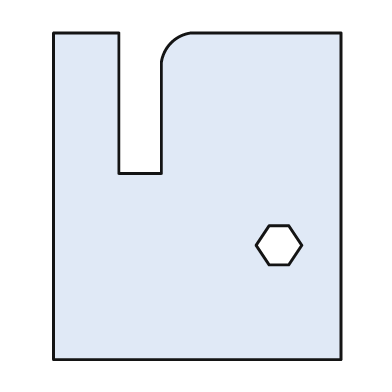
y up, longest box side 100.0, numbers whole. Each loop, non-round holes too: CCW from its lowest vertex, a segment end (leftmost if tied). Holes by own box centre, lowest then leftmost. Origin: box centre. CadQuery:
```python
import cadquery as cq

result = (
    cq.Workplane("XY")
    .moveTo(-44.0, -50.0)
    .lineTo(44.0, -50.0)
    .lineTo(44.0, 50.0)
    .lineTo(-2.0, 50.0)
    .threePointArc((-8.0, 47.0), (-11.0, 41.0))
    .lineTo(-11.0, 7.0)
    .lineTo(-24.0, 7.0)
    .lineTo(-24.0, 50.0)
    .lineTo(-44.0, 50.0)
    .close()
    .moveTo(22.0, -21.0)
    .lineTo(28.0, -21.0)
    .lineTo(32.0, -15.0)
    .lineTo(28.0, -9.0)
    .lineTo(22.0, -9.0)
    .lineTo(18.0, -15.0)
    .close()
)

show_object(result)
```